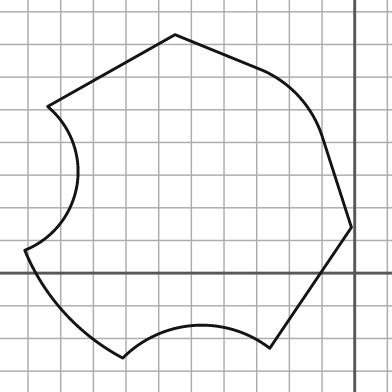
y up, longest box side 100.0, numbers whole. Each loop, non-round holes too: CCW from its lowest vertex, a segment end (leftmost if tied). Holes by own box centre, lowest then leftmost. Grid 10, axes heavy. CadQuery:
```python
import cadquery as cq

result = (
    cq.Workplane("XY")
    .moveTo(-71.0, -26.0)
    .threePointArc((-49.0, -16.0), (-26.0, -23.0))
    .lineTo(-1.0, 14.0)
    .lineTo(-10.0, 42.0)
    .threePointArc((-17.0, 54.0), (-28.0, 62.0))
    .lineTo(-55.0, 73.0)
    .lineTo(-94.0, 51.0)
    .threePointArc((-85.0, 27.0), (-101.0, 7.0))
    .threePointArc((-89.0, -12.0), (-71.0, -26.0))
    .close()
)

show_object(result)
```